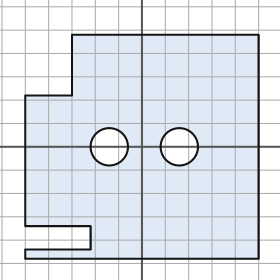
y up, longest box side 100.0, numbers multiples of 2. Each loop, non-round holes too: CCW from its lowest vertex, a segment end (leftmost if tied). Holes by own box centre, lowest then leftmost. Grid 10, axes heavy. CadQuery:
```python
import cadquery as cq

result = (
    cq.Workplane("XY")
    .moveTo(-50.0, -48.0)
    .lineTo(50.0, -48.0)
    .lineTo(50.0, 48.0)
    .lineTo(-30.0, 48.0)
    .lineTo(-30.0, 22.0)
    .lineTo(-50.0, 22.0)
    .lineTo(-50.0, -34.0)
    .lineTo(-22.0, -34.0)
    .lineTo(-22.0, -44.0)
    .lineTo(-50.0, -44.0)
    .close()
    .moveTo(-14.0, 0.0)
    .circle(8.0)
    .moveTo(16.0, 0.0)
    .circle(8.0)
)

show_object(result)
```